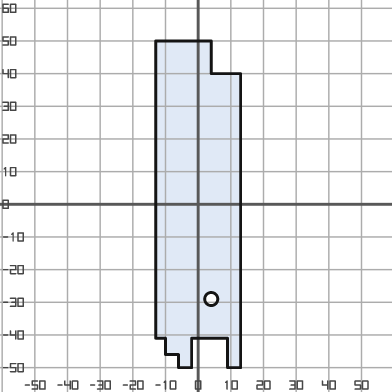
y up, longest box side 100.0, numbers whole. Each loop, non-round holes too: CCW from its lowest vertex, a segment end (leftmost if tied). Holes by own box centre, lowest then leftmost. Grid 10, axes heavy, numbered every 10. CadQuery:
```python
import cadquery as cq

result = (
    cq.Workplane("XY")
    .moveTo(-6.0, -50.0)
    .lineTo(-2.0, -50.0)
    .lineTo(-2.0, -41.0)
    .lineTo(9.0, -41.0)
    .lineTo(9.0, -50.0)
    .lineTo(13.0, -50.0)
    .lineTo(13.0, 40.0)
    .lineTo(4.0, 40.0)
    .lineTo(4.0, 50.0)
    .lineTo(-13.0, 50.0)
    .lineTo(-13.0, -41.0)
    .lineTo(-10.0, -41.0)
    .lineTo(-10.0, -46.0)
    .lineTo(-6.0, -46.0)
    .close()
    .moveTo(4.0, -29.0)
    .circle(2.0)
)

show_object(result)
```